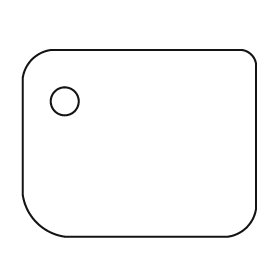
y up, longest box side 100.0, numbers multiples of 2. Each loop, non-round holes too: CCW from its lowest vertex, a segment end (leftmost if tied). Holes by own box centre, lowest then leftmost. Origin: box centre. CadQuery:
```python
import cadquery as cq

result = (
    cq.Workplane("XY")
    .moveTo(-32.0, -40.0)
    .lineTo(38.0, -40.0)
    .threePointArc((46.0, -36.0), (50.0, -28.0))
    .lineTo(50.0, 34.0)
    .threePointArc((48.0, 38.0), (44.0, 40.0))
    .lineTo(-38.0, 40.0)
    .threePointArc((-46.0, 36.0), (-50.0, 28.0))
    .lineTo(-50.0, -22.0)
    .threePointArc((-44.0, -34.0), (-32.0, -40.0))
    .close()
    .moveTo(-32.0, 18.0)
    .circle(6.0)
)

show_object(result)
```